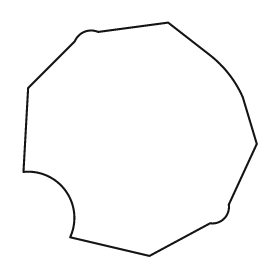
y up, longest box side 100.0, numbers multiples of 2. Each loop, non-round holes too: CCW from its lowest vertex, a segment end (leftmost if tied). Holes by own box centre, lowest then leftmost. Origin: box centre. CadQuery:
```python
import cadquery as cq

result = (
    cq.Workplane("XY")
    .moveTo(4.0, -50.0)
    .lineTo(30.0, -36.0)
    .threePointArc((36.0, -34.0), (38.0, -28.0))
    .lineTo(50.0, -2.0)
    .lineTo(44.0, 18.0)
    .threePointArc((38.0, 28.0), (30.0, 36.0))
    .lineTo(12.0, 50.0)
    .lineTo(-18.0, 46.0)
    .threePointArc((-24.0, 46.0), (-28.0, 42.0))
    .lineTo(-48.0, 22.0)
    .lineTo(-50.0, -14.0)
    .threePointArc((-32.0, -22.0), (-30.0, -42.0))
    .close()
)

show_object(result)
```